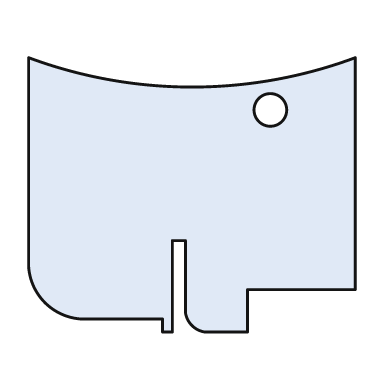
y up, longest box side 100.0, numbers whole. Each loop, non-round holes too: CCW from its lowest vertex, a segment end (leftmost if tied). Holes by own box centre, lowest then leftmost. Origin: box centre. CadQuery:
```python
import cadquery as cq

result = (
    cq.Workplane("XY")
    .moveTo(-9.0, -42.0)
    .lineTo(-6.0, -42.0)
    .lineTo(-6.0, -14.0)
    .lineTo(-2.0, -14.0)
    .lineTo(-2.0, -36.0)
    .threePointArc((0.0, -40.0), (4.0, -42.0))
    .lineTo(17.0, -42.0)
    .lineTo(17.0, -29.0)
    .lineTo(50.0, -29.0)
    .lineTo(50.0, 42.0)
    .threePointArc((0.0, 33.0), (-50.0, 42.0))
    .lineTo(-50.0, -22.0)
    .threePointArc((-45.0, -33.0), (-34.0, -38.0))
    .lineTo(-9.0, -38.0)
    .close()
    .moveTo(24.0, 26.0)
    .circle(5.0)
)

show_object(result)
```